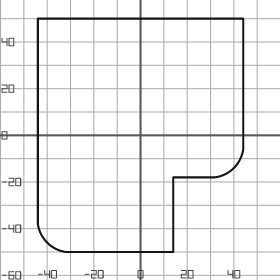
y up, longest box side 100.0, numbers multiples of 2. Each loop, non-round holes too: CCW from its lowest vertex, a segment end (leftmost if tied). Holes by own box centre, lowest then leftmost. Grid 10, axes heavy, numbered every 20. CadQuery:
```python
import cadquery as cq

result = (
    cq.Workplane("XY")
    .moveTo(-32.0, -50.0)
    .lineTo(14.0, -50.0)
    .lineTo(14.0, -18.0)
    .lineTo(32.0, -18.0)
    .threePointArc((40.0, -14.0), (44.0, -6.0))
    .lineTo(44.0, 50.0)
    .lineTo(-44.0, 50.0)
    .lineTo(-44.0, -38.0)
    .threePointArc((-40.0, -46.0), (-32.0, -50.0))
    .close()
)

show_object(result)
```